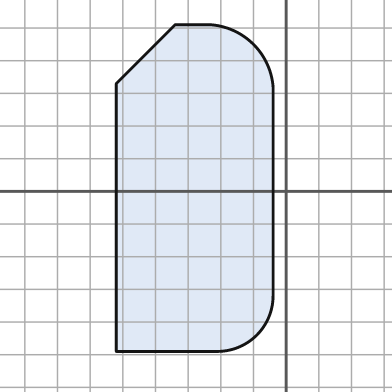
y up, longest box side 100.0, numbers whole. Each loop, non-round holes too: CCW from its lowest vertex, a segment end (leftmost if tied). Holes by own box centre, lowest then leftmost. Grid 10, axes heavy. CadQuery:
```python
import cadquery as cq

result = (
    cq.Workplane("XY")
    .moveTo(-52.0, -49.0)
    .lineTo(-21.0, -49.0)
    .threePointArc((-9.0, -44.0), (-4.0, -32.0))
    .lineTo(-4.0, 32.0)
    .threePointArc((-10.0, 45.0), (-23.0, 51.0))
    .lineTo(-34.0, 51.0)
    .lineTo(-52.0, 33.0)
    .close()
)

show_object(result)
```